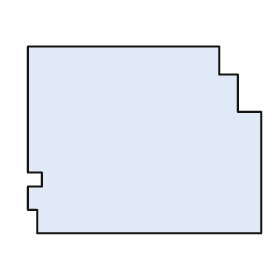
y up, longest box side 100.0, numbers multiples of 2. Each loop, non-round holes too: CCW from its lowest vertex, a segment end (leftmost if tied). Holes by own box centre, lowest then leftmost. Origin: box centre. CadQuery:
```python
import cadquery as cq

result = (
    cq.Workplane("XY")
    .moveTo(-46.0, -40.0)
    .lineTo(50.0, -40.0)
    .lineTo(50.0, 12.0)
    .lineTo(40.0, 12.0)
    .lineTo(40.0, 28.0)
    .lineTo(32.0, 28.0)
    .lineTo(32.0, 40.0)
    .lineTo(-50.0, 40.0)
    .lineTo(-50.0, -14.0)
    .lineTo(-44.0, -14.0)
    .lineTo(-44.0, -20.0)
    .lineTo(-50.0, -20.0)
    .lineTo(-50.0, -30.0)
    .lineTo(-46.0, -30.0)
    .close()
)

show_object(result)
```